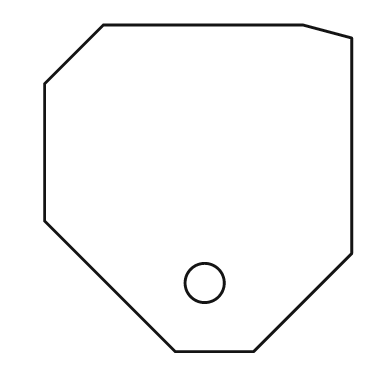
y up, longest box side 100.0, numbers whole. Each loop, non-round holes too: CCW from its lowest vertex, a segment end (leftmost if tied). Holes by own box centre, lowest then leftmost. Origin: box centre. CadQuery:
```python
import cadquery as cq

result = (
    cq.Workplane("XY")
    .moveTo(-7.0, -50.0)
    .lineTo(17.0, -50.0)
    .lineTo(47.0, -20.0)
    .lineTo(47.0, 46.0)
    .lineTo(32.0, 50.0)
    .lineTo(-29.0, 50.0)
    .lineTo(-47.0, 32.0)
    .lineTo(-47.0, -10.0)
    .close()
    .moveTo(2.0, -29.0)
    .circle(6.0)
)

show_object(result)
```